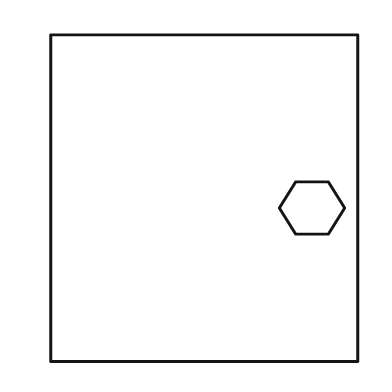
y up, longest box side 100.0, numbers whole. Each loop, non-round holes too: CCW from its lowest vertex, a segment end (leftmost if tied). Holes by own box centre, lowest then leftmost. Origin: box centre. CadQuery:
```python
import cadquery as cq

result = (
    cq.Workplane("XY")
    .moveTo(-47.0, -50.0)
    .lineTo(47.0, -50.0)
    .lineTo(47.0, 50.0)
    .lineTo(-47.0, 50.0)
    .close()
    .moveTo(28.0, -11.0)
    .lineTo(38.0, -11.0)
    .lineTo(43.0, -3.0)
    .lineTo(38.0, 5.0)
    .lineTo(28.0, 5.0)
    .lineTo(23.0, -3.0)
    .close()
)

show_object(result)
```